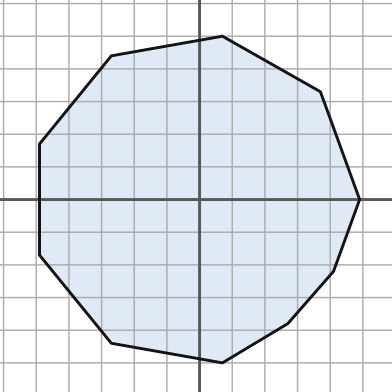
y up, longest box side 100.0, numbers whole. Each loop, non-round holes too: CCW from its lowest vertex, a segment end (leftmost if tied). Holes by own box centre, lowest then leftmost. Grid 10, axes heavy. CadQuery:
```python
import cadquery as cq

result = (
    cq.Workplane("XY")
    .moveTo(7.0, -50.0)
    .lineTo(27.0, -38.0)
    .lineTo(41.0, -22.0)
    .lineTo(49.0, 0.0)
    .lineTo(37.0, 33.0)
    .lineTo(7.0, 50.0)
    .lineTo(-27.0, 44.0)
    .lineTo(-49.0, 17.0)
    .lineTo(-49.0, -17.0)
    .lineTo(-27.0, -44.0)
    .close()
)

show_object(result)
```